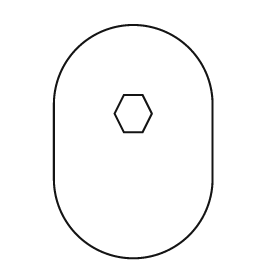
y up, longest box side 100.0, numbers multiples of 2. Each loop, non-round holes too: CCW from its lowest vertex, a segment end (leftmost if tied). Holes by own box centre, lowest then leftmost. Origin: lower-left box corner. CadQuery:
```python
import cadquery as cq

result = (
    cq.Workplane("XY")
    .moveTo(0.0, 34.0)
    .threePointArc((34.0, 0.0), (68.0, 34.0))
    .lineTo(68.0, 66.0)
    .threePointArc((34.0, 100.0), (0.0, 66.0))
    .close()
    .moveTo(30.0, 54.0)
    .lineTo(38.0, 54.0)
    .lineTo(42.0, 62.0)
    .lineTo(38.0, 70.0)
    .lineTo(30.0, 70.0)
    .lineTo(26.0, 62.0)
    .close()
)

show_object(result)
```